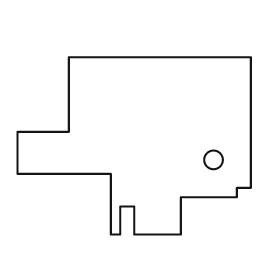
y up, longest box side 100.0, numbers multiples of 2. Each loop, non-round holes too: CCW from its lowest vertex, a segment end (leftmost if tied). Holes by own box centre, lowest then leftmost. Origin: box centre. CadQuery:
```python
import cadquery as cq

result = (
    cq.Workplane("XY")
    .moveTo(-10.0, -38.0)
    .lineTo(-6.0, -38.0)
    .lineTo(-6.0, -26.0)
    .lineTo(0.0, -26.0)
    .lineTo(0.0, -38.0)
    .lineTo(20.0, -38.0)
    .lineTo(20.0, -22.0)
    .lineTo(44.0, -22.0)
    .lineTo(44.0, -18.0)
    .lineTo(50.0, -18.0)
    .lineTo(50.0, 38.0)
    .lineTo(-28.0, 38.0)
    .lineTo(-28.0, 6.0)
    .lineTo(-50.0, 6.0)
    .lineTo(-50.0, -12.0)
    .lineTo(-10.0, -12.0)
    .close()
    .moveTo(34.0, -6.0)
    .circle(4.0)
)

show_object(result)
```